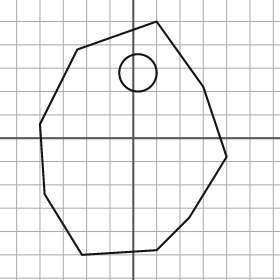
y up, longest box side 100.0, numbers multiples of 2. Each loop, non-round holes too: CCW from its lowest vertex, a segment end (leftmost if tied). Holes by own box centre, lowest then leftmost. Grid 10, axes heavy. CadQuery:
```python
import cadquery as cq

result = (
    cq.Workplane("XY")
    .moveTo(-22.0, -50.0)
    .lineTo(10.0, -48.0)
    .lineTo(24.0, -34.0)
    .lineTo(40.0, -8.0)
    .lineTo(30.0, 22.0)
    .lineTo(10.0, 50.0)
    .lineTo(-24.0, 38.0)
    .lineTo(-40.0, 6.0)
    .lineTo(-38.0, -24.0)
    .close()
    .moveTo(2.0, 28.0)
    .circle(8.0)
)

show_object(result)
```